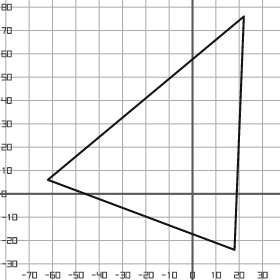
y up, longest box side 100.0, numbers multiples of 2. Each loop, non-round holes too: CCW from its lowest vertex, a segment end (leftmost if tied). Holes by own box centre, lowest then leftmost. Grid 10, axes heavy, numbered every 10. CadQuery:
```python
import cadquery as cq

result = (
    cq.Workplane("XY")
    .moveTo(18.0, -24.0)
    .lineTo(22.0, 76.0)
    .lineTo(-62.0, 6.0)
    .close()
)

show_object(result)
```